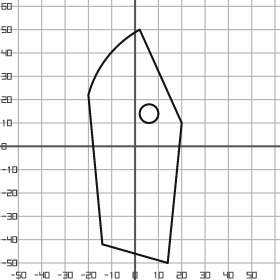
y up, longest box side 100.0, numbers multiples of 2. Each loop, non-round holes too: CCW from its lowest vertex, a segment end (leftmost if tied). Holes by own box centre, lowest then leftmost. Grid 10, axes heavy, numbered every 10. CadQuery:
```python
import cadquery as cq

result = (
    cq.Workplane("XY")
    .moveTo(14.0, -50.0)
    .lineTo(20.0, 10.0)
    .lineTo(2.0, 50.0)
    .threePointArc((-12.0, 38.0), (-20.0, 22.0))
    .lineTo(-14.0, -42.0)
    .close()
    .moveTo(6.0, 14.0)
    .circle(4.0)
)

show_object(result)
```